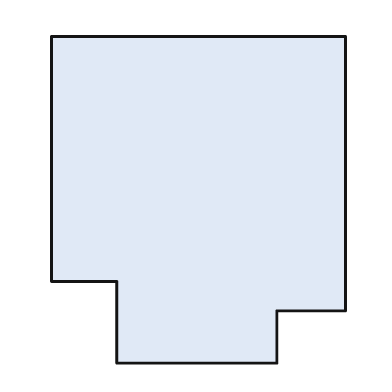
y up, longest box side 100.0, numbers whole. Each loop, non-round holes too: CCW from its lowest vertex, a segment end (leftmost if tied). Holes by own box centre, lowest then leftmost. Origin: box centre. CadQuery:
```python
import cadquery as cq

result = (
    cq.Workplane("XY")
    .moveTo(-25.0, -50.0)
    .lineTo(24.0, -50.0)
    .lineTo(24.0, -34.0)
    .lineTo(45.0, -34.0)
    .lineTo(45.0, 50.0)
    .lineTo(-45.0, 50.0)
    .lineTo(-45.0, -25.0)
    .lineTo(-25.0, -25.0)
    .close()
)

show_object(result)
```